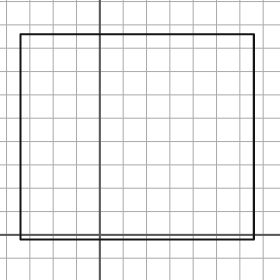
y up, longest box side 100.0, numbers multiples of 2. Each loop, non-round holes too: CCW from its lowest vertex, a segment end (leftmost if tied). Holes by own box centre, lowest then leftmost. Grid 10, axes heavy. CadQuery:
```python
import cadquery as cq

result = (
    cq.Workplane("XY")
    .moveTo(-34.0, -2.0)
    .lineTo(66.0, -2.0)
    .lineTo(66.0, 86.0)
    .lineTo(-34.0, 86.0)
    .close()
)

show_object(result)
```